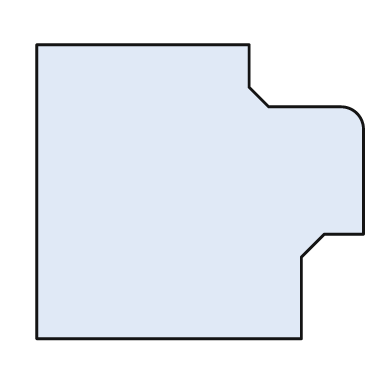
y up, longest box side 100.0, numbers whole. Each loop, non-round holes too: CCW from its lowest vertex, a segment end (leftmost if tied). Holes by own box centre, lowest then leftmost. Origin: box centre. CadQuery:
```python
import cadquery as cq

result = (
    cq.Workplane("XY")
    .moveTo(-50.0, -45.0)
    .lineTo(31.0, -45.0)
    .lineTo(31.0, -20.0)
    .lineTo(38.0, -13.0)
    .lineTo(50.0, -13.0)
    .lineTo(50.0, 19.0)
    .threePointArc((48.0, 24.0), (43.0, 26.0))
    .lineTo(21.0, 26.0)
    .lineTo(15.0, 32.0)
    .lineTo(15.0, 45.0)
    .lineTo(-50.0, 45.0)
    .close()
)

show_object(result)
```